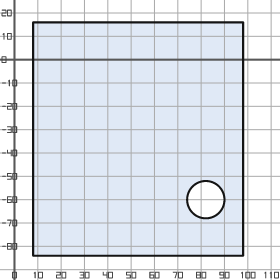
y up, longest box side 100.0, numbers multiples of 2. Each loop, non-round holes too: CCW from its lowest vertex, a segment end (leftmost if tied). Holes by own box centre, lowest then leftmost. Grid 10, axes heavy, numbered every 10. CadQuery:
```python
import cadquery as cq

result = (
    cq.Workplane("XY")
    .moveTo(8.0, -84.0)
    .lineTo(98.0, -84.0)
    .lineTo(98.0, 16.0)
    .lineTo(8.0, 16.0)
    .close()
    .moveTo(82.0, -60.0)
    .circle(8.0)
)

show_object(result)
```